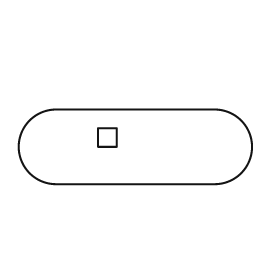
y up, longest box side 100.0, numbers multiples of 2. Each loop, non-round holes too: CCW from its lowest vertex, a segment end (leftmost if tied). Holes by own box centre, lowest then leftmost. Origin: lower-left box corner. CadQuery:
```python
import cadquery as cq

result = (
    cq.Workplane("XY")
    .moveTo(16.0, 0.0)
    .lineTo(84.0, 0.0)
    .threePointArc((100.0, 16.0), (84.0, 32.0))
    .lineTo(16.0, 32.0)
    .threePointArc((0.0, 16.0), (16.0, 0.0))
    .close()
    .moveTo(34.0, 16.0)
    .lineTo(42.0, 16.0)
    .lineTo(42.0, 24.0)
    .lineTo(34.0, 24.0)
    .close()
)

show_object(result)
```